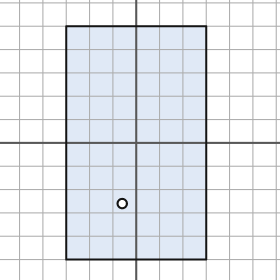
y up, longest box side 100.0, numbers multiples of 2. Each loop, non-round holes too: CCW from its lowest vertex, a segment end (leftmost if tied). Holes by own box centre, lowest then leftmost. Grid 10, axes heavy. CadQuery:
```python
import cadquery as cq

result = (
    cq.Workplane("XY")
    .moveTo(-30.0, -50.0)
    .lineTo(30.0, -50.0)
    .lineTo(30.0, 50.0)
    .lineTo(-30.0, 50.0)
    .close()
    .moveTo(-6.0, -26.0)
    .circle(2.0)
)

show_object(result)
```